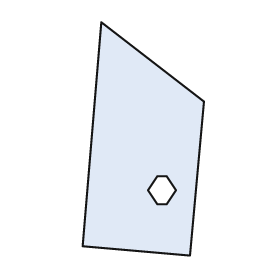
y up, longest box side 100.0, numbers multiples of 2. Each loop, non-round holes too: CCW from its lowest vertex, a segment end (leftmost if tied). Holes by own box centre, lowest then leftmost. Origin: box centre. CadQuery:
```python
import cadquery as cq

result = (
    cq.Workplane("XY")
    .moveTo(20.0, -50.0)
    .lineTo(26.0, 16.0)
    .lineTo(-18.0, 50.0)
    .lineTo(-26.0, -46.0)
    .close()
    .moveTo(6.0, -28.0)
    .lineTo(10.0, -28.0)
    .lineTo(14.0, -22.0)
    .lineTo(10.0, -16.0)
    .lineTo(6.0, -16.0)
    .lineTo(2.0, -22.0)
    .close()
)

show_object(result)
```